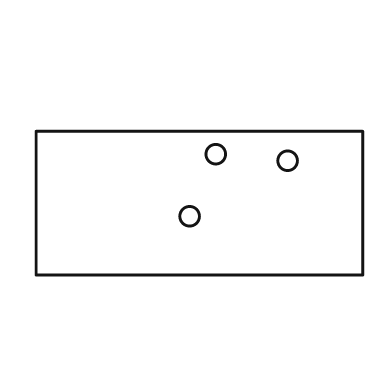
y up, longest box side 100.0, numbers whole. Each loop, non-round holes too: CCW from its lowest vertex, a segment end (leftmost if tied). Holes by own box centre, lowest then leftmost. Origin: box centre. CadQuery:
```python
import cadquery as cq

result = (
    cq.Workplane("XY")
    .moveTo(-50.0, -22.0)
    .lineTo(50.0, -22.0)
    .lineTo(50.0, 22.0)
    .lineTo(-50.0, 22.0)
    .close()
    .moveTo(-3.0, -4.0)
    .circle(3.0)
    .moveTo(27.0, 13.0)
    .circle(3.0)
    .moveTo(5.0, 15.0)
    .circle(3.0)
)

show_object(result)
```